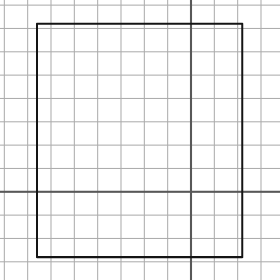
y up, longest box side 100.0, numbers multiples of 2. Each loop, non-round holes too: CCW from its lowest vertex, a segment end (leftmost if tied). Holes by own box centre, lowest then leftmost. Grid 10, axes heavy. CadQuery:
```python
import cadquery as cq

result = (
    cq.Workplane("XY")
    .moveTo(-66.0, -28.0)
    .lineTo(22.0, -28.0)
    .lineTo(22.0, 72.0)
    .lineTo(-66.0, 72.0)
    .close()
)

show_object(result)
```